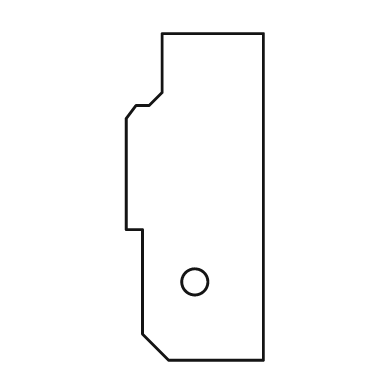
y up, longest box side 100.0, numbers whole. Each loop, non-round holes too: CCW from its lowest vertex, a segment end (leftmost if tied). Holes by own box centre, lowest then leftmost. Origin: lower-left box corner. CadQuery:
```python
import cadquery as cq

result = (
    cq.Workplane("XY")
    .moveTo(13.0, 0.0)
    .lineTo(42.0, 0.0)
    .lineTo(42.0, 100.0)
    .lineTo(11.0, 100.0)
    .lineTo(11.0, 82.0)
    .lineTo(7.0, 78.0)
    .lineTo(3.0, 78.0)
    .lineTo(0.0, 74.0)
    .lineTo(0.0, 40.0)
    .lineTo(5.0, 40.0)
    .lineTo(5.0, 8.0)
    .close()
    .moveTo(21.0, 24.0)
    .circle(4.0)
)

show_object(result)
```